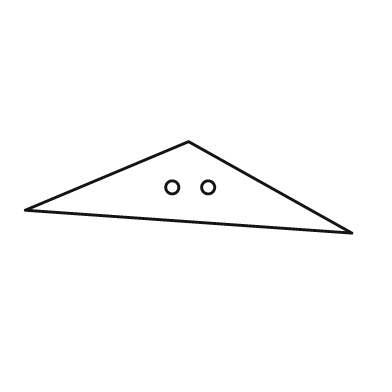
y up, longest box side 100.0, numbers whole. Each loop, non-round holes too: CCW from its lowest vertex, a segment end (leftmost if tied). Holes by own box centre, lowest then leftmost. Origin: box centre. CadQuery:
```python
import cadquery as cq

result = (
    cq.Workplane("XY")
    .moveTo(50.0, -14.0)
    .lineTo(0.0, 14.0)
    .lineTo(-50.0, -7.0)
    .close()
    .moveTo(-5.0, 0.0)
    .circle(2.0)
    .moveTo(6.0, 0.0)
    .circle(2.0)
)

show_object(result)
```